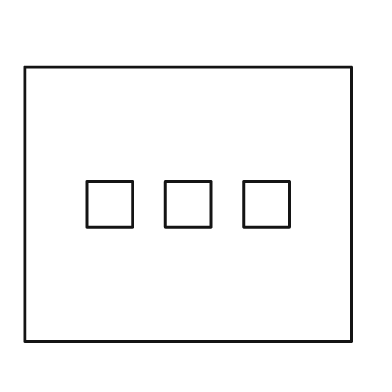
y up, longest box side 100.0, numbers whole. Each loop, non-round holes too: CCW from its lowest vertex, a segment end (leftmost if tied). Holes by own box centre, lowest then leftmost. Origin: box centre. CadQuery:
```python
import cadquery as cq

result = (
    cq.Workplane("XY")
    .moveTo(-50.0, -42.0)
    .lineTo(50.0, -42.0)
    .lineTo(50.0, 42.0)
    .lineTo(-50.0, 42.0)
    .close()
    .moveTo(-31.0, -7.0)
    .lineTo(-17.0, -7.0)
    .lineTo(-17.0, 7.0)
    .lineTo(-31.0, 7.0)
    .close()
    .moveTo(-7.0, -7.0)
    .lineTo(7.0, -7.0)
    .lineTo(7.0, 7.0)
    .lineTo(-7.0, 7.0)
    .close()
    .moveTo(17.0, -7.0)
    .lineTo(31.0, -7.0)
    .lineTo(31.0, 7.0)
    .lineTo(17.0, 7.0)
    .close()
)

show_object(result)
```